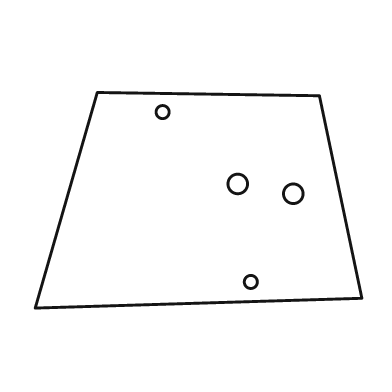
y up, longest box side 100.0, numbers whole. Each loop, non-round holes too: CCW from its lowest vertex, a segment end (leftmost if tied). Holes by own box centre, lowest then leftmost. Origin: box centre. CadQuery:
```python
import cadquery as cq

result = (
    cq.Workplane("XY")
    .moveTo(-50.0, -33.0)
    .lineTo(50.0, -30.0)
    .lineTo(37.0, 32.0)
    .lineTo(-31.0, 33.0)
    .close()
    .moveTo(16.0, -25.0)
    .circle(2.0)
    .moveTo(29.0, 2.0)
    .circle(3.0)
    .moveTo(12.0, 5.0)
    .circle(3.0)
    .moveTo(-11.0, 27.0)
    .circle(2.0)
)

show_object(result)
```